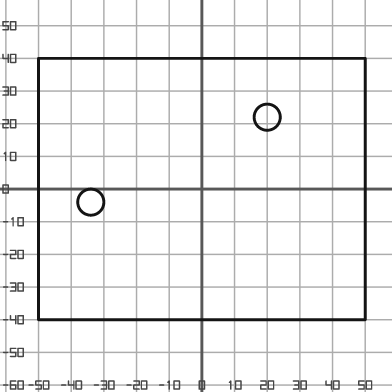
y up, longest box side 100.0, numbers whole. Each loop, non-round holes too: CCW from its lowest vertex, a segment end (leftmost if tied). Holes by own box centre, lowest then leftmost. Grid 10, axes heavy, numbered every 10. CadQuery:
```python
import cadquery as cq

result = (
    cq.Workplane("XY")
    .moveTo(-50.0, -40.0)
    .lineTo(50.0, -40.0)
    .lineTo(50.0, 40.0)
    .lineTo(-50.0, 40.0)
    .close()
    .moveTo(-34.0, -4.0)
    .circle(4.0)
    .moveTo(20.0, 22.0)
    .circle(4.0)
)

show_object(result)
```